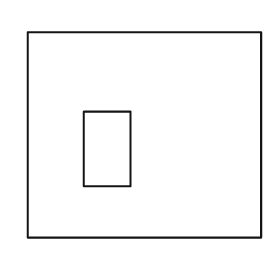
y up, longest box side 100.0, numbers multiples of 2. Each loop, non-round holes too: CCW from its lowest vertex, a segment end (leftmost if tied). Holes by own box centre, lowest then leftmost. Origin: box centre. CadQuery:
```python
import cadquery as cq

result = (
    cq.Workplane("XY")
    .moveTo(-50.0, -44.0)
    .lineTo(50.0, -44.0)
    .lineTo(50.0, 44.0)
    .lineTo(-50.0, 44.0)
    .close()
    .moveTo(-26.0, -22.0)
    .lineTo(-6.0, -22.0)
    .lineTo(-6.0, 10.0)
    .lineTo(-26.0, 10.0)
    .close()
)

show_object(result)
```